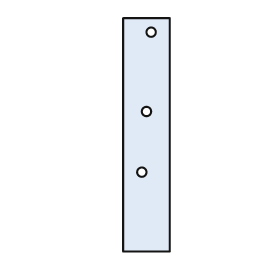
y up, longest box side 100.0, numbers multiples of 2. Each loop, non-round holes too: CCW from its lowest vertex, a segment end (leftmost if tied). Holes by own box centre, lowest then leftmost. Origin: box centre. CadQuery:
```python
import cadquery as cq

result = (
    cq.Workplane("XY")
    .moveTo(-10.0, -50.0)
    .lineTo(10.0, -50.0)
    .lineTo(10.0, 50.0)
    .lineTo(-10.0, 50.0)
    .close()
    .moveTo(-2.0, -16.0)
    .circle(2.0)
    .moveTo(0.0, 10.0)
    .circle(2.0)
    .moveTo(2.0, 44.0)
    .circle(2.0)
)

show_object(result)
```